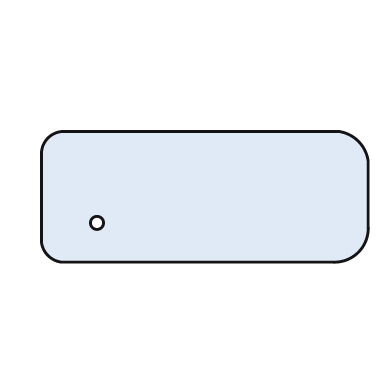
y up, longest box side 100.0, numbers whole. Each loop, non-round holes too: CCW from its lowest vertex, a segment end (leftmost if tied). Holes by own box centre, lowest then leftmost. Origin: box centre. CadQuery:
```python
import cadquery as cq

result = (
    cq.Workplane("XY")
    .moveTo(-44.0, -20.0)
    .lineTo(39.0, -20.0)
    .threePointArc((47.0, -17.0), (50.0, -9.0))
    .lineTo(50.0, 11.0)
    .threePointArc((47.0, 17.0), (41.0, 20.0))
    .lineTo(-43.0, 20.0)
    .threePointArc((-48.0, 18.0), (-50.0, 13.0))
    .lineTo(-50.0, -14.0)
    .threePointArc((-48.0, -18.0), (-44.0, -20.0))
    .close()
    .moveTo(-33.0, -8.0)
    .circle(2.0)
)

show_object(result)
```